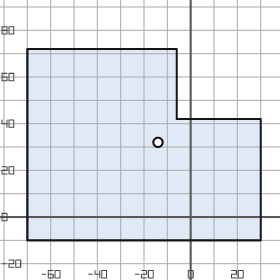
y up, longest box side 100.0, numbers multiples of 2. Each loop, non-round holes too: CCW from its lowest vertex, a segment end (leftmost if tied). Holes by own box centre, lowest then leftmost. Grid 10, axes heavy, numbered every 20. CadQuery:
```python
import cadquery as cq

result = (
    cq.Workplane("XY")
    .moveTo(-70.0, -10.0)
    .lineTo(30.0, -10.0)
    .lineTo(30.0, 42.0)
    .lineTo(-6.0, 42.0)
    .lineTo(-6.0, 72.0)
    .lineTo(-70.0, 72.0)
    .close()
    .moveTo(-14.0, 32.0)
    .circle(2.0)
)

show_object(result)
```